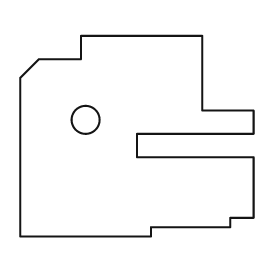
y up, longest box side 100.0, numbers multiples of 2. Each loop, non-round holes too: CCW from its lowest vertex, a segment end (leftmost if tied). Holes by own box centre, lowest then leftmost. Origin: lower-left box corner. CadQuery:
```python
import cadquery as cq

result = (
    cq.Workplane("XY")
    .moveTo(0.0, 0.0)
    .lineTo(56.0, 0.0)
    .lineTo(56.0, 4.0)
    .lineTo(90.0, 4.0)
    .lineTo(90.0, 8.0)
    .lineTo(100.0, 8.0)
    .lineTo(100.0, 34.0)
    .lineTo(50.0, 34.0)
    .lineTo(50.0, 44.0)
    .lineTo(100.0, 44.0)
    .lineTo(100.0, 54.0)
    .lineTo(78.0, 54.0)
    .lineTo(78.0, 86.0)
    .lineTo(26.0, 86.0)
    .lineTo(26.0, 76.0)
    .lineTo(8.0, 76.0)
    .lineTo(0.0, 68.0)
    .close()
    .moveTo(28.0, 50.0)
    .circle(6.0)
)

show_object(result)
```